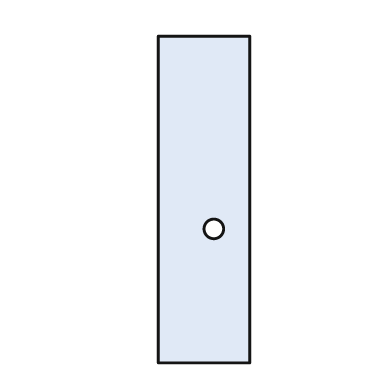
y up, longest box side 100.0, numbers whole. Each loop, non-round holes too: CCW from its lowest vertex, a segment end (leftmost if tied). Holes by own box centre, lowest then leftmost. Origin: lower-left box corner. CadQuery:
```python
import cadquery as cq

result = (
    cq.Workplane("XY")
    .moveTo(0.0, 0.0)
    .lineTo(28.0, 0.0)
    .lineTo(28.0, 100.0)
    .lineTo(0.0, 100.0)
    .close()
    .moveTo(17.0, 41.0)
    .circle(3.0)
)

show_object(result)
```